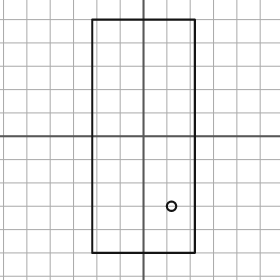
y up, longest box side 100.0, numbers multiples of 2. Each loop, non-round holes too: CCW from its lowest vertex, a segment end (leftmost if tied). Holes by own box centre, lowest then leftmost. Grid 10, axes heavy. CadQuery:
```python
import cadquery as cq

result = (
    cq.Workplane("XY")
    .moveTo(-22.0, -50.0)
    .lineTo(22.0, -50.0)
    .lineTo(22.0, 50.0)
    .lineTo(-22.0, 50.0)
    .close()
    .moveTo(12.0, -30.0)
    .circle(2.0)
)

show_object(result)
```